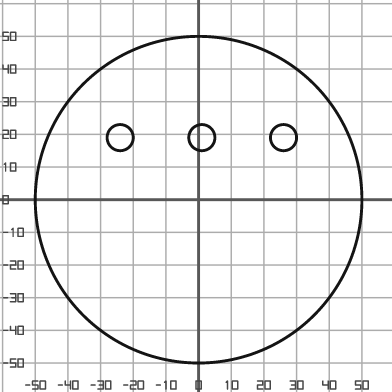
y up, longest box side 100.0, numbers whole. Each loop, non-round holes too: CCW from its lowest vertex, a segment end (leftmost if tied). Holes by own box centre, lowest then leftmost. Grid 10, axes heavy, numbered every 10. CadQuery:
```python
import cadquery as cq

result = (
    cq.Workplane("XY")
    .moveTo(0.0, 0.0)
    .circle(50.0)
    .moveTo(-24.0, 19.0)
    .circle(4.0)
    .moveTo(1.0, 19.0)
    .circle(4.0)
    .moveTo(26.0, 19.0)
    .circle(4.0)
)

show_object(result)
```